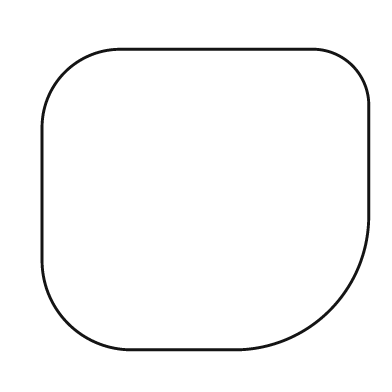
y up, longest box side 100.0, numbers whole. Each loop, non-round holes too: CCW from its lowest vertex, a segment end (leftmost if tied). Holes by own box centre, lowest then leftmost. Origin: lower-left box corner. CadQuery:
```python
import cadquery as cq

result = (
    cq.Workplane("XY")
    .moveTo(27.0, 0.0)
    .lineTo(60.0, 0.0)
    .threePointArc((88.0, 12.0), (100.0, 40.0))
    .lineTo(100.0, 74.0)
    .threePointArc((95.0, 87.0), (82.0, 92.0))
    .lineTo(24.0, 92.0)
    .threePointArc((7.0, 85.0), (0.0, 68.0))
    .lineTo(0.0, 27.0)
    .threePointArc((8.0, 8.0), (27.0, 0.0))
    .close()
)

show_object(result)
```